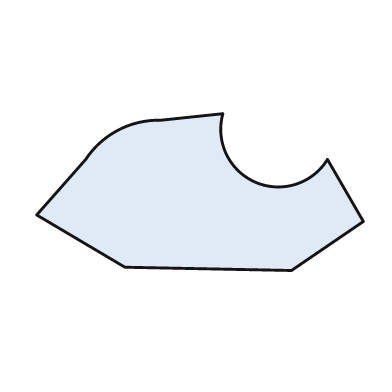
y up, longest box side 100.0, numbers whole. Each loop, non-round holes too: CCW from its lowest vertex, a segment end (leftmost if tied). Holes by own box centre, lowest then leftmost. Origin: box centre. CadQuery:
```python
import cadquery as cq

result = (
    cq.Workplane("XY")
    .moveTo(28.0, -24.0)
    .lineTo(50.0, -9.0)
    .lineTo(39.0, 10.0)
    .threePointArc((17.0, 3.0), (7.0, 24.0))
    .lineTo(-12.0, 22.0)
    .threePointArc((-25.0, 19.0), (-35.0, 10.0))
    .lineTo(-50.0, -7.0)
    .lineTo(-23.0, -23.0)
    .close()
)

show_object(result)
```